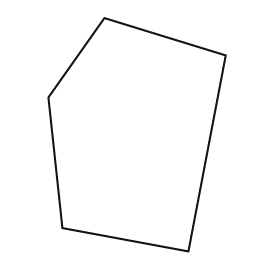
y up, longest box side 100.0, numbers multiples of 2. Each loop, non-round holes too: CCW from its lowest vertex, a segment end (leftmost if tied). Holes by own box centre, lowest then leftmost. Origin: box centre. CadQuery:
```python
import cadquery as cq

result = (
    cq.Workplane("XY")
    .moveTo(22.0, -50.0)
    .lineTo(38.0, 34.0)
    .lineTo(-14.0, 50.0)
    .lineTo(-38.0, 16.0)
    .lineTo(-32.0, -40.0)
    .close()
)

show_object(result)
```